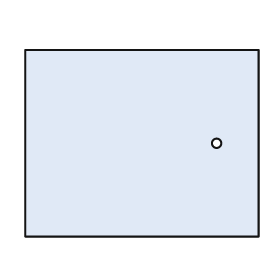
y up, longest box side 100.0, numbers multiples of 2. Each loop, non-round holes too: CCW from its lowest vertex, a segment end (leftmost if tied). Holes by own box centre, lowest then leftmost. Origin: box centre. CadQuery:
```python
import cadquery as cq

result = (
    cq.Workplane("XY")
    .moveTo(-50.0, -40.0)
    .lineTo(50.0, -40.0)
    .lineTo(50.0, 40.0)
    .lineTo(-50.0, 40.0)
    .close()
    .moveTo(32.0, 0.0)
    .circle(2.0)
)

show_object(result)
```